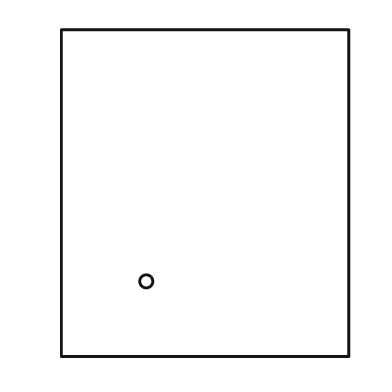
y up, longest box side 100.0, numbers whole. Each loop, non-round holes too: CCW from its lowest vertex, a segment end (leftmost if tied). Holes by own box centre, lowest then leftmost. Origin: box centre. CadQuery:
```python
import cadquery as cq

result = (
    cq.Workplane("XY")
    .moveTo(-44.0, -50.0)
    .lineTo(44.0, -50.0)
    .lineTo(44.0, 50.0)
    .lineTo(-44.0, 50.0)
    .close()
    .moveTo(-18.0, -27.0)
    .circle(2.0)
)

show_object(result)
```